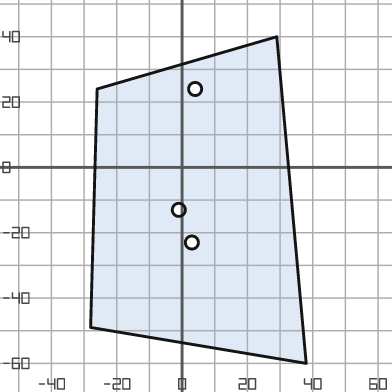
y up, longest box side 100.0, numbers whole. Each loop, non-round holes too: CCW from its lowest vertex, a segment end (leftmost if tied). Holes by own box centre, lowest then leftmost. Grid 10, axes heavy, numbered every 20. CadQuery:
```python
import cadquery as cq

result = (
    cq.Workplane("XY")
    .moveTo(38.0, -60.0)
    .lineTo(29.0, 40.0)
    .lineTo(-26.0, 24.0)
    .lineTo(-28.0, -49.0)
    .close()
    .moveTo(3.0, -23.0)
    .circle(2.0)
    .moveTo(-1.0, -13.0)
    .circle(2.0)
    .moveTo(4.0, 24.0)
    .circle(2.0)
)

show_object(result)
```